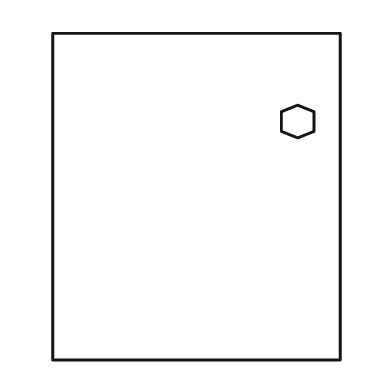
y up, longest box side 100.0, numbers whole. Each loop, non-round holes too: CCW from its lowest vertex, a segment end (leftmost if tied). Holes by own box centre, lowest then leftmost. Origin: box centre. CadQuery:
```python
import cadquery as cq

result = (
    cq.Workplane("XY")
    .moveTo(-44.0, -50.0)
    .lineTo(44.0, -50.0)
    .lineTo(44.0, 50.0)
    .lineTo(-44.0, 50.0)
    .close()
    .moveTo(31.0, 18.0)
    .lineTo(36.0, 20.0)
    .lineTo(36.0, 26.0)
    .lineTo(31.0, 28.0)
    .lineTo(26.0, 26.0)
    .lineTo(26.0, 20.0)
    .close()
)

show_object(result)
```